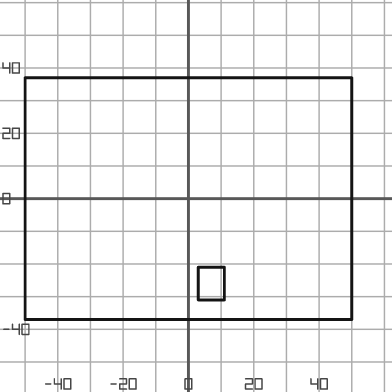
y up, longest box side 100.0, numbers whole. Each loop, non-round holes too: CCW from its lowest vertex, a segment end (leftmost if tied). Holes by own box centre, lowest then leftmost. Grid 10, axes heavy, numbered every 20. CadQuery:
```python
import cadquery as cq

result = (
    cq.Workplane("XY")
    .moveTo(-50.0, -37.0)
    .lineTo(50.0, -37.0)
    .lineTo(50.0, 37.0)
    .lineTo(-50.0, 37.0)
    .close()
    .moveTo(3.0, -31.0)
    .lineTo(11.0, -31.0)
    .lineTo(11.0, -21.0)
    .lineTo(3.0, -21.0)
    .close()
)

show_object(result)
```